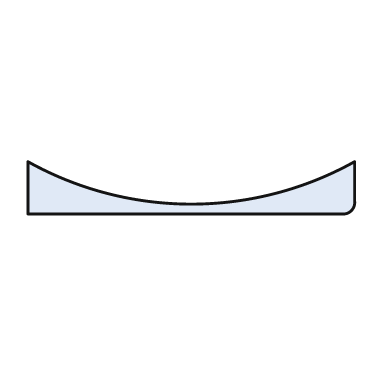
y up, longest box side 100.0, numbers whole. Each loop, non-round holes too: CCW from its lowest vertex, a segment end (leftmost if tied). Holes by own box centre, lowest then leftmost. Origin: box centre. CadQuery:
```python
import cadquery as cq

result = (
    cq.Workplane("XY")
    .moveTo(-50.0, -8.0)
    .lineTo(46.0, -8.0)
    .threePointArc((49.0, -7.0), (50.0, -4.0))
    .lineTo(50.0, 8.0)
    .threePointArc((0.0, -5.0), (-50.0, 8.0))
    .close()
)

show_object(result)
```